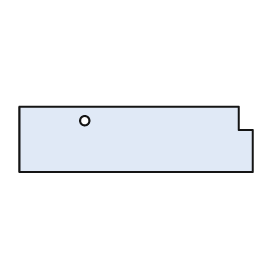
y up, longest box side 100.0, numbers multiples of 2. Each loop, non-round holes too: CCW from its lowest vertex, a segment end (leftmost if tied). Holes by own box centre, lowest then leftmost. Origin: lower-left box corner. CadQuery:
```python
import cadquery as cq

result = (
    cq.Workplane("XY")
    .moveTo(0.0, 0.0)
    .lineTo(100.0, 0.0)
    .lineTo(100.0, 18.0)
    .lineTo(94.0, 18.0)
    .lineTo(94.0, 28.0)
    .lineTo(0.0, 28.0)
    .close()
    .moveTo(28.0, 22.0)
    .circle(2.0)
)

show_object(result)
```